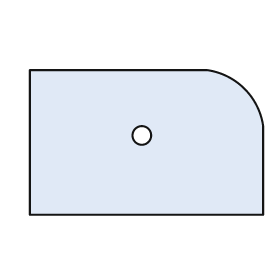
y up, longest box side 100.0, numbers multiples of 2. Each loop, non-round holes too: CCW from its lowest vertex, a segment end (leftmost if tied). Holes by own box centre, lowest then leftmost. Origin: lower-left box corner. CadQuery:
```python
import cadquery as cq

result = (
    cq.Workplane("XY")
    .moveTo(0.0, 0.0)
    .lineTo(100.0, 0.0)
    .lineTo(100.0, 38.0)
    .threePointArc((92.0, 54.0), (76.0, 62.0))
    .lineTo(0.0, 62.0)
    .close()
    .moveTo(48.0, 34.0)
    .circle(4.0)
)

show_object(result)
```